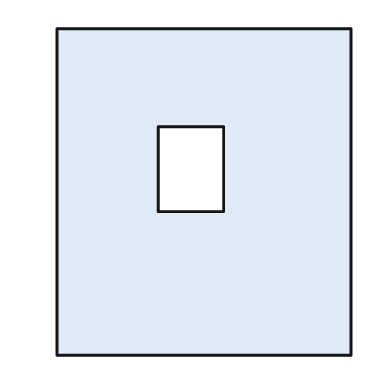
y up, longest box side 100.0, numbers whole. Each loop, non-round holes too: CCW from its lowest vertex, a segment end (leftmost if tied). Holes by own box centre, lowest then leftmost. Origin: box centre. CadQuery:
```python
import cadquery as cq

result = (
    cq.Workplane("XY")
    .moveTo(-45.0, -50.0)
    .lineTo(45.0, -50.0)
    .lineTo(45.0, 50.0)
    .lineTo(-45.0, 50.0)
    .close()
    .moveTo(-14.0, -6.0)
    .lineTo(6.0, -6.0)
    .lineTo(6.0, 20.0)
    .lineTo(-14.0, 20.0)
    .close()
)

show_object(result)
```